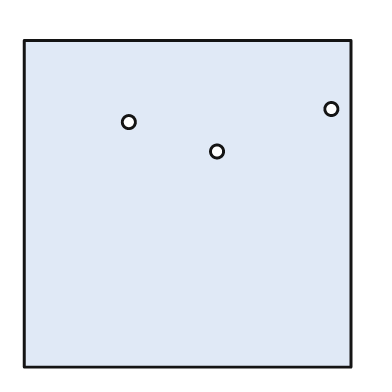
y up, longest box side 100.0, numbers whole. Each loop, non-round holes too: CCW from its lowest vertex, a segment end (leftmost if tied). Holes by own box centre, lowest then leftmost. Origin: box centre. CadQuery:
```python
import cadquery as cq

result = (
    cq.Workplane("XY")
    .moveTo(-50.0, -50.0)
    .lineTo(50.0, -50.0)
    .lineTo(50.0, 50.0)
    .lineTo(-50.0, 50.0)
    .close()
    .moveTo(9.0, 16.0)
    .circle(2.0)
    .moveTo(-18.0, 25.0)
    .circle(2.0)
    .moveTo(44.0, 29.0)
    .circle(2.0)
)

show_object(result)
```